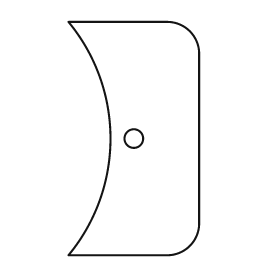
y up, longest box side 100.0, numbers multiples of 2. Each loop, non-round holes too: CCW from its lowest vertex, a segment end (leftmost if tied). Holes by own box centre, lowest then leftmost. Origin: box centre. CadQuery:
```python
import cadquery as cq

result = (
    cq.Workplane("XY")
    .moveTo(-28.0, -50.0)
    .lineTo(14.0, -50.0)
    .threePointArc((24.0, -46.0), (28.0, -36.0))
    .lineTo(28.0, 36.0)
    .threePointArc((24.0, 46.0), (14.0, 50.0))
    .lineTo(-28.0, 50.0)
    .threePointArc((-10.0, 0.0), (-28.0, -50.0))
    .close()
    .moveTo(0.0, 0.0)
    .circle(4.0)
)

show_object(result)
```